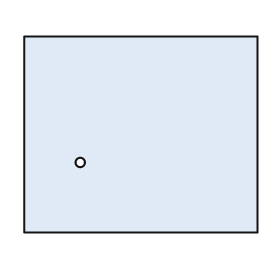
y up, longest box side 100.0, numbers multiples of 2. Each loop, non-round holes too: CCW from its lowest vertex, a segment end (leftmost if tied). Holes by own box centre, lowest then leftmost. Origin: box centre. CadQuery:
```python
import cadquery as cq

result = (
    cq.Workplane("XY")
    .moveTo(-50.0, -42.0)
    .lineTo(50.0, -42.0)
    .lineTo(50.0, 42.0)
    .lineTo(-50.0, 42.0)
    .close()
    .moveTo(-26.0, -12.0)
    .circle(2.0)
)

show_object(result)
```